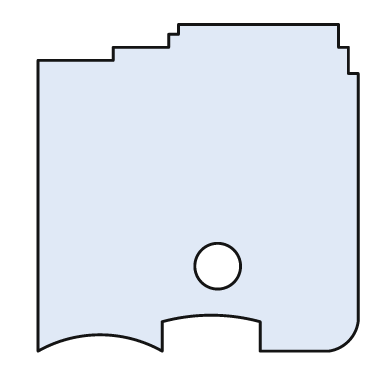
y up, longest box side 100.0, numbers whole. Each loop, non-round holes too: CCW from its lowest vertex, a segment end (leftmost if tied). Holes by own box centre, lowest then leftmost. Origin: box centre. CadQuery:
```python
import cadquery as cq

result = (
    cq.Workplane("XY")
    .moveTo(-49.0, -50.0)
    .threePointArc((-30.0, -45.0), (-11.0, -50.0))
    .lineTo(-11.0, -41.0)
    .threePointArc((4.0, -39.0), (19.0, -41.0))
    .lineTo(19.0, -50.0)
    .lineTo(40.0, -50.0)
    .threePointArc((46.0, -47.0), (49.0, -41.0))
    .lineTo(49.0, 35.0)
    .lineTo(46.0, 35.0)
    .lineTo(46.0, 43.0)
    .lineTo(43.0, 43.0)
    .lineTo(43.0, 50.0)
    .lineTo(-6.0, 50.0)
    .lineTo(-6.0, 47.0)
    .lineTo(-9.0, 47.0)
    .lineTo(-9.0, 43.0)
    .lineTo(-26.0, 43.0)
    .lineTo(-26.0, 39.0)
    .lineTo(-49.0, 39.0)
    .close()
    .moveTo(6.0, -24.0)
    .circle(7.0)
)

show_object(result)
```